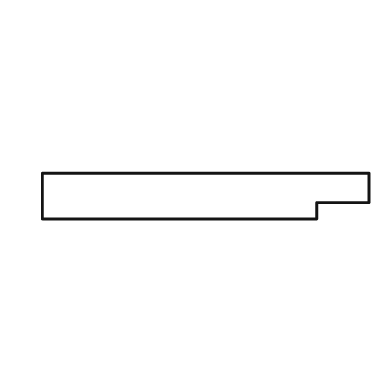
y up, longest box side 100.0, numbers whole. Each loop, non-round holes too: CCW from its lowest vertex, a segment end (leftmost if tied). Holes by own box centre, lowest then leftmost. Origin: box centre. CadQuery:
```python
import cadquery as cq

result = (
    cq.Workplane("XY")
    .moveTo(-50.0, -7.0)
    .lineTo(34.0, -7.0)
    .lineTo(34.0, -2.0)
    .lineTo(50.0, -2.0)
    .lineTo(50.0, 7.0)
    .lineTo(-50.0, 7.0)
    .close()
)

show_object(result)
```